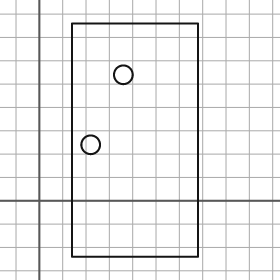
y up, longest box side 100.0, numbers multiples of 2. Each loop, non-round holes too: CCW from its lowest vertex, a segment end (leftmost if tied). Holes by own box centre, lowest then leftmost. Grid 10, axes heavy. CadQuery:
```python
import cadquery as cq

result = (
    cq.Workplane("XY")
    .moveTo(14.0, -24.0)
    .lineTo(68.0, -24.0)
    .lineTo(68.0, 76.0)
    .lineTo(14.0, 76.0)
    .close()
    .moveTo(22.0, 24.0)
    .circle(4.0)
    .moveTo(36.0, 54.0)
    .circle(4.0)
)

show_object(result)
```